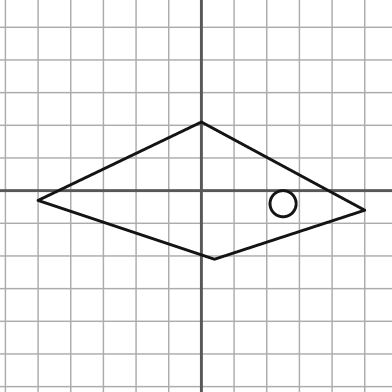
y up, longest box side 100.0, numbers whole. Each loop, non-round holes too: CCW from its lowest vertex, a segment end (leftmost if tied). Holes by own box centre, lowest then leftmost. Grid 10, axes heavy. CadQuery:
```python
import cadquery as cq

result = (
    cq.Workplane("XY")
    .moveTo(4.0, -21.0)
    .lineTo(50.0, -6.0)
    .lineTo(0.0, 21.0)
    .lineTo(-50.0, -3.0)
    .close()
    .moveTo(25.0, -4.0)
    .circle(4.0)
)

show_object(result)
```